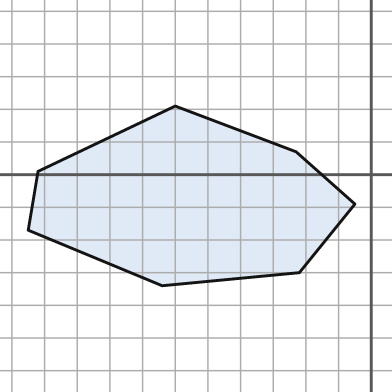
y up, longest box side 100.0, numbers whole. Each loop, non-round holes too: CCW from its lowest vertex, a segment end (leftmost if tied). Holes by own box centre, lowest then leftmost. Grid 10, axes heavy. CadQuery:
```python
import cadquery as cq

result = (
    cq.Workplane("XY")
    .moveTo(-64.0, -34.0)
    .lineTo(-22.0, -30.0)
    .lineTo(-5.0, -9.0)
    .lineTo(-23.0, 7.0)
    .lineTo(-60.0, 21.0)
    .lineTo(-102.0, 1.0)
    .lineTo(-105.0, -17.0)
    .close()
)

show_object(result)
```